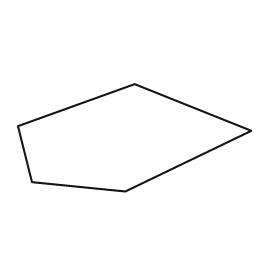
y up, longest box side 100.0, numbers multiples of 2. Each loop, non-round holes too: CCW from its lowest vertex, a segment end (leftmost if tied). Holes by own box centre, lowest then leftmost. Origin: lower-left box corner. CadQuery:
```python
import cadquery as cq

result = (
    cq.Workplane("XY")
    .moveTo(46.0, 0.0)
    .lineTo(100.0, 26.0)
    .lineTo(50.0, 46.0)
    .lineTo(0.0, 28.0)
    .lineTo(6.0, 4.0)
    .close()
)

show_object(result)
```